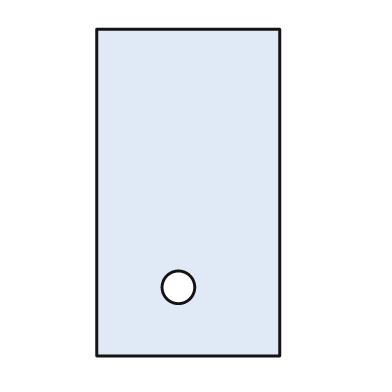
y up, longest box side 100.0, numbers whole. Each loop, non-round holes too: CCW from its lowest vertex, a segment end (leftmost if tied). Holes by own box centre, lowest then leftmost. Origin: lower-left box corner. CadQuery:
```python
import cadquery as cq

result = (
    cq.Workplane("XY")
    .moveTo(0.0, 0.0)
    .lineTo(56.0, 0.0)
    .lineTo(56.0, 100.0)
    .lineTo(0.0, 100.0)
    .close()
    .moveTo(25.0, 21.0)
    .circle(5.0)
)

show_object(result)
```